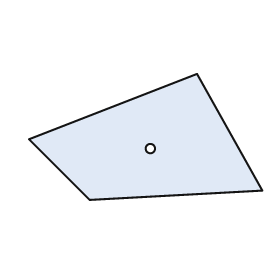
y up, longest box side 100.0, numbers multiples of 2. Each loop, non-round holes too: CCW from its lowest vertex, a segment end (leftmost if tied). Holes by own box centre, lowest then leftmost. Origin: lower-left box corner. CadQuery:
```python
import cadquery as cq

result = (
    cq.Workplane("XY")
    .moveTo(26.0, 0.0)
    .lineTo(100.0, 4.0)
    .lineTo(72.0, 54.0)
    .lineTo(0.0, 26.0)
    .close()
    .moveTo(52.0, 22.0)
    .circle(2.0)
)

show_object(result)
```